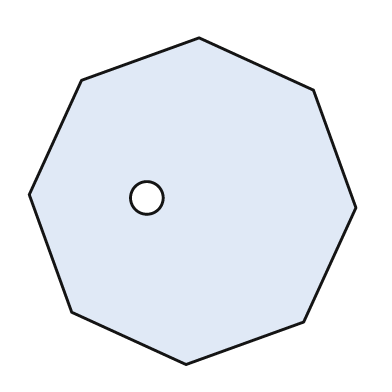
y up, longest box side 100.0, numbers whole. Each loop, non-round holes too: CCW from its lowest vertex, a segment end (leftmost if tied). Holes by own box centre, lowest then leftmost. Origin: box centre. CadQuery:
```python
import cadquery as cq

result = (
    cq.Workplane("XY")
    .moveTo(-2.0, -50.0)
    .lineTo(34.0, -37.0)
    .lineTo(50.0, -2.0)
    .lineTo(37.0, 34.0)
    .lineTo(2.0, 50.0)
    .lineTo(-34.0, 37.0)
    .lineTo(-50.0, 2.0)
    .lineTo(-37.0, -34.0)
    .close()
    .moveTo(-14.0, 1.0)
    .circle(5.0)
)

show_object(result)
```